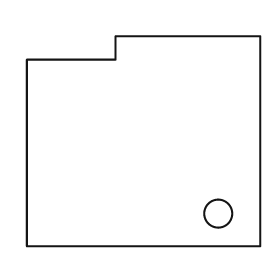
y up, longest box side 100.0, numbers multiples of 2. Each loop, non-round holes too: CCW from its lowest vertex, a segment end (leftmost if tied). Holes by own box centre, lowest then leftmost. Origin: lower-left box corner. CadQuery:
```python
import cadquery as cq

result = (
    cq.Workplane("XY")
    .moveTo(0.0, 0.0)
    .lineTo(100.0, 0.0)
    .lineTo(100.0, 90.0)
    .lineTo(38.0, 90.0)
    .lineTo(38.0, 80.0)
    .lineTo(0.0, 80.0)
    .close()
    .moveTo(82.0, 14.0)
    .circle(6.0)
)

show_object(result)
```